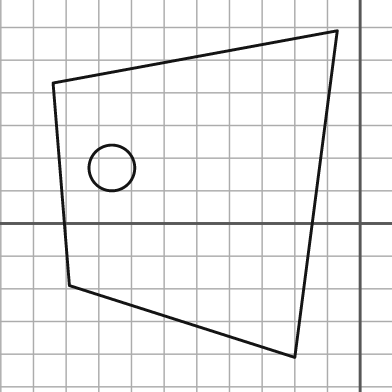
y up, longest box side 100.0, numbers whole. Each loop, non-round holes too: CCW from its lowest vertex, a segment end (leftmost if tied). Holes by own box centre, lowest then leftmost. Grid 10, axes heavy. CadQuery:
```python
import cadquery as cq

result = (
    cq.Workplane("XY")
    .moveTo(-20.0, -41.0)
    .lineTo(-7.0, 59.0)
    .lineTo(-94.0, 43.0)
    .lineTo(-89.0, -19.0)
    .close()
    .moveTo(-76.0, 17.0)
    .circle(7.0)
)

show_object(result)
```